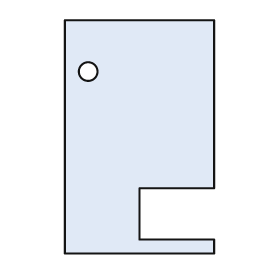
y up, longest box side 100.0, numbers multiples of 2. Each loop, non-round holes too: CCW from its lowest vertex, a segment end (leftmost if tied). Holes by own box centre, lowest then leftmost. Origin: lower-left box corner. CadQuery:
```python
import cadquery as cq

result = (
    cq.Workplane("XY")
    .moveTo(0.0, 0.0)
    .lineTo(64.0, 0.0)
    .lineTo(64.0, 6.0)
    .lineTo(32.0, 6.0)
    .lineTo(32.0, 28.0)
    .lineTo(64.0, 28.0)
    .lineTo(64.0, 100.0)
    .lineTo(0.0, 100.0)
    .close()
    .moveTo(10.0, 78.0)
    .circle(4.0)
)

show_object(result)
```